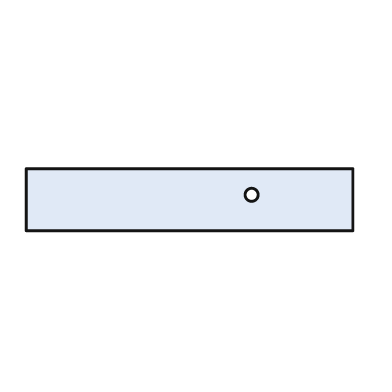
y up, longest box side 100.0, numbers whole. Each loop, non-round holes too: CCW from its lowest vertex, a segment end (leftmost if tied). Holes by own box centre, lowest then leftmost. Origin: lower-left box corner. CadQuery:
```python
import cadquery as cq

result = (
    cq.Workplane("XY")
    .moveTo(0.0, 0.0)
    .lineTo(100.0, 0.0)
    .lineTo(100.0, 19.0)
    .lineTo(0.0, 19.0)
    .close()
    .moveTo(69.0, 11.0)
    .circle(2.0)
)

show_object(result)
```